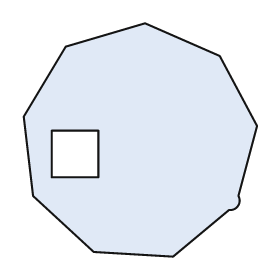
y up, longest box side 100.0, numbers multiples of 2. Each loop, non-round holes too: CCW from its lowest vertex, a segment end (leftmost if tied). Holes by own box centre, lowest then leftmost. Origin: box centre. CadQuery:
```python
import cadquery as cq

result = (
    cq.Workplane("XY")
    .moveTo(14.0, -50.0)
    .lineTo(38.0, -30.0)
    .threePointArc((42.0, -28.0), (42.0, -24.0))
    .lineTo(50.0, 6.0)
    .lineTo(34.0, 36.0)
    .lineTo(2.0, 50.0)
    .lineTo(-32.0, 40.0)
    .lineTo(-50.0, 10.0)
    .lineTo(-46.0, -24.0)
    .lineTo(-20.0, -48.0)
    .close()
    .moveTo(-38.0, -16.0)
    .lineTo(-18.0, -16.0)
    .lineTo(-18.0, 4.0)
    .lineTo(-38.0, 4.0)
    .close()
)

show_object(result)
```